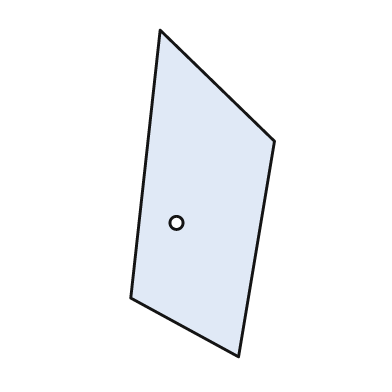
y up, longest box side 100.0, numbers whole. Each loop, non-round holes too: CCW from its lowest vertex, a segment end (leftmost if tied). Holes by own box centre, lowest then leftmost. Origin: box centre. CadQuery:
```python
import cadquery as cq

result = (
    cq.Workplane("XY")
    .moveTo(11.0, -50.0)
    .lineTo(22.0, 16.0)
    .lineTo(-13.0, 50.0)
    .lineTo(-22.0, -32.0)
    .close()
    .moveTo(-8.0, -9.0)
    .circle(2.0)
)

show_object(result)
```